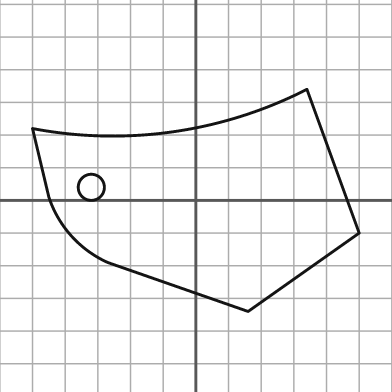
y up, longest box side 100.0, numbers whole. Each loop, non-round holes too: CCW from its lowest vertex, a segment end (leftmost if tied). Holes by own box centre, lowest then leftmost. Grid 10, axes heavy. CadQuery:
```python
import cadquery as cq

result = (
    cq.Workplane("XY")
    .moveTo(16.0, -34.0)
    .lineTo(50.0, -10.0)
    .lineTo(34.0, 34.0)
    .threePointArc((-7.0, 21.0), (-50.0, 22.0))
    .lineTo(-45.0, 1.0)
    .threePointArc((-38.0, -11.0), (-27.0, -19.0))
    .close()
    .moveTo(-32.0, 4.0)
    .circle(4.0)
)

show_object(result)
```